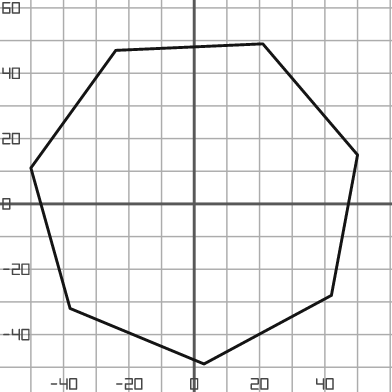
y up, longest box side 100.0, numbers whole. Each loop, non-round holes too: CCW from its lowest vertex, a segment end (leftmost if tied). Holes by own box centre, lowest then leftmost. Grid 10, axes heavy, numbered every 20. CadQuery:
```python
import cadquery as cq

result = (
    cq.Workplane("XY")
    .moveTo(3.0, -49.0)
    .lineTo(42.0, -28.0)
    .lineTo(50.0, 15.0)
    .lineTo(21.0, 49.0)
    .lineTo(-24.0, 47.0)
    .lineTo(-50.0, 11.0)
    .lineTo(-38.0, -32.0)
    .close()
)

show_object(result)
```